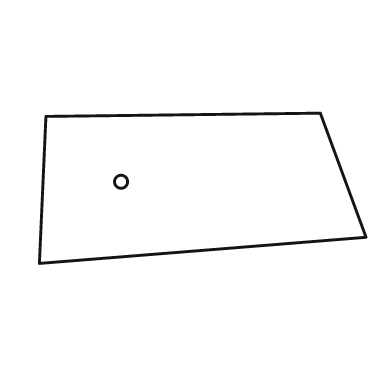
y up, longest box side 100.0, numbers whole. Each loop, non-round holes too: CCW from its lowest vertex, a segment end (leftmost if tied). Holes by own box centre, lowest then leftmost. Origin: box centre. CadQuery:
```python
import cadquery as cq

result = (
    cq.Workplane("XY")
    .moveTo(-50.0, -23.0)
    .lineTo(50.0, -15.0)
    .lineTo(36.0, 23.0)
    .lineTo(-48.0, 22.0)
    .close()
    .moveTo(-25.0, 2.0)
    .circle(2.0)
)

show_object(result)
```